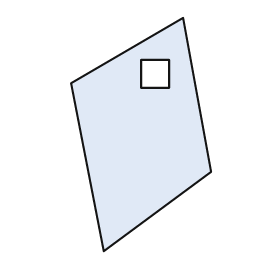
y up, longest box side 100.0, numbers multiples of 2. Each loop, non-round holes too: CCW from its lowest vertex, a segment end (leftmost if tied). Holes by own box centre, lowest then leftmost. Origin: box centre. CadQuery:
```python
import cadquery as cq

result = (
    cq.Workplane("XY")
    .moveTo(-16.0, -50.0)
    .lineTo(30.0, -16.0)
    .lineTo(18.0, 50.0)
    .lineTo(-30.0, 22.0)
    .close()
    .moveTo(0.0, 20.0)
    .lineTo(12.0, 20.0)
    .lineTo(12.0, 32.0)
    .lineTo(0.0, 32.0)
    .close()
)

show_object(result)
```